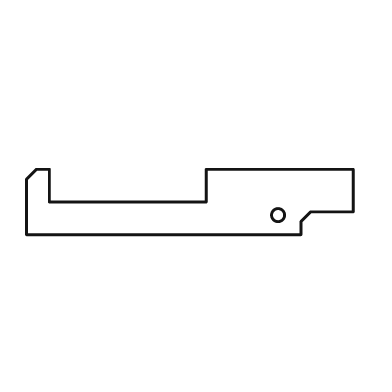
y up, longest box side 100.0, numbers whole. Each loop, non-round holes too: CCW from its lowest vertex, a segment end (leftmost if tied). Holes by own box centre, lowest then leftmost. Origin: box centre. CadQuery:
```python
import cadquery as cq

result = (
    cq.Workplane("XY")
    .moveTo(-50.0, -10.0)
    .lineTo(34.0, -10.0)
    .lineTo(34.0, -6.0)
    .lineTo(37.0, -3.0)
    .lineTo(50.0, -3.0)
    .lineTo(50.0, 10.0)
    .lineTo(5.0, 10.0)
    .lineTo(5.0, 0.0)
    .lineTo(-43.0, 0.0)
    .lineTo(-43.0, 10.0)
    .lineTo(-47.0, 10.0)
    .lineTo(-50.0, 7.0)
    .close()
    .moveTo(27.0, -4.0)
    .circle(2.0)
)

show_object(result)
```